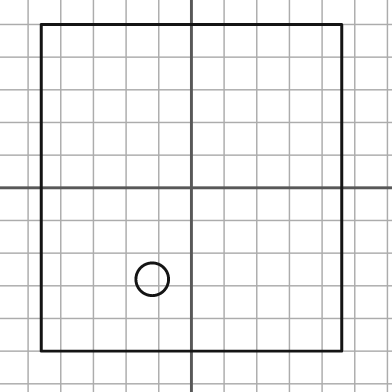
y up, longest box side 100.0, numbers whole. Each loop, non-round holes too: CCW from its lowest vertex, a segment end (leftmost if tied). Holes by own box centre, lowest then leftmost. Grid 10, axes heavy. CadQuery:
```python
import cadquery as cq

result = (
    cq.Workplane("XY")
    .moveTo(-46.0, -50.0)
    .lineTo(46.0, -50.0)
    .lineTo(46.0, 50.0)
    .lineTo(-46.0, 50.0)
    .close()
    .moveTo(-12.0, -28.0)
    .circle(5.0)
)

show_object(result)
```